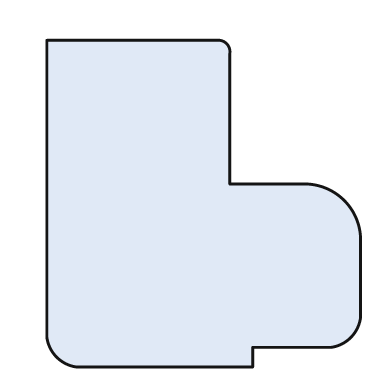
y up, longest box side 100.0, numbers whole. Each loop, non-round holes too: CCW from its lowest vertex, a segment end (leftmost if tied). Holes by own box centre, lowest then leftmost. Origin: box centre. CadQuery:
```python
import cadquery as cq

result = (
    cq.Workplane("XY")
    .moveTo(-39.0, -50.0)
    .lineTo(15.0, -50.0)
    .lineTo(15.0, -44.0)
    .lineTo(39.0, -44.0)
    .threePointArc((45.0, -41.0), (48.0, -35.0))
    .lineTo(48.0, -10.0)
    .threePointArc((43.0, 1.0), (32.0, 6.0))
    .lineTo(8.0, 6.0)
    .lineTo(8.0, 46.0)
    .threePointArc((7.0, 49.0), (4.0, 50.0))
    .lineTo(-48.0, 50.0)
    .lineTo(-48.0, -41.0)
    .threePointArc((-45.0, -47.0), (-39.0, -50.0))
    .close()
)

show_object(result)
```